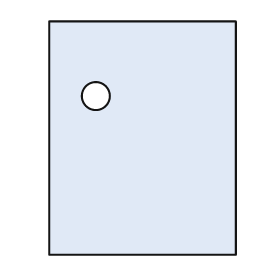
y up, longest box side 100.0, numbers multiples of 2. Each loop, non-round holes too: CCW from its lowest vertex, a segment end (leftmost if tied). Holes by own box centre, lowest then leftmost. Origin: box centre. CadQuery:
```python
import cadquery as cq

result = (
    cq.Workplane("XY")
    .moveTo(-40.0, -50.0)
    .lineTo(40.0, -50.0)
    .lineTo(40.0, 50.0)
    .lineTo(-40.0, 50.0)
    .close()
    .moveTo(-20.0, 18.0)
    .circle(6.0)
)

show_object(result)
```